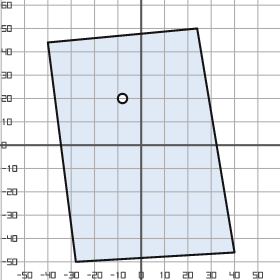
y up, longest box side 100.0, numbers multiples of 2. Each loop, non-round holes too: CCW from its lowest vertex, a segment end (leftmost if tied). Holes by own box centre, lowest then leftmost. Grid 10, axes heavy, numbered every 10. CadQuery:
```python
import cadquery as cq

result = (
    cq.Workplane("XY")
    .moveTo(-28.0, -50.0)
    .lineTo(40.0, -46.0)
    .lineTo(24.0, 50.0)
    .lineTo(-40.0, 44.0)
    .close()
    .moveTo(-8.0, 20.0)
    .circle(2.0)
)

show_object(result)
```